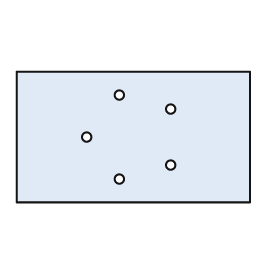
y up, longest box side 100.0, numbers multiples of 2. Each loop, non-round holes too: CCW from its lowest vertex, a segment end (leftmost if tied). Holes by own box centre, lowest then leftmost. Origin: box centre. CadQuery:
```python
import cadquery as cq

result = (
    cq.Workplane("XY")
    .moveTo(-50.0, -28.0)
    .lineTo(50.0, -28.0)
    .lineTo(50.0, 28.0)
    .lineTo(-50.0, 28.0)
    .close()
    .moveTo(-6.0, -18.0)
    .circle(2.0)
    .moveTo(16.0, -12.0)
    .circle(2.0)
    .moveTo(-20.0, 0.0)
    .circle(2.0)
    .moveTo(16.0, 12.0)
    .circle(2.0)
    .moveTo(-6.0, 18.0)
    .circle(2.0)
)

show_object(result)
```